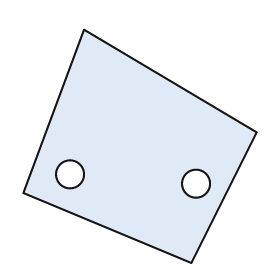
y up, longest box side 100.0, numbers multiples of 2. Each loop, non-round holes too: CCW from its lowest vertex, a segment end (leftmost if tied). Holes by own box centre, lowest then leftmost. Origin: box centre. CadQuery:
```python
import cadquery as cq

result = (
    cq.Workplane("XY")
    .moveTo(22.0, -50.0)
    .lineTo(50.0, 6.0)
    .lineTo(-24.0, 50.0)
    .lineTo(-50.0, -20.0)
    .close()
    .moveTo(24.0, -16.0)
    .circle(6.0)
    .moveTo(-30.0, -12.0)
    .circle(6.0)
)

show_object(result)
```